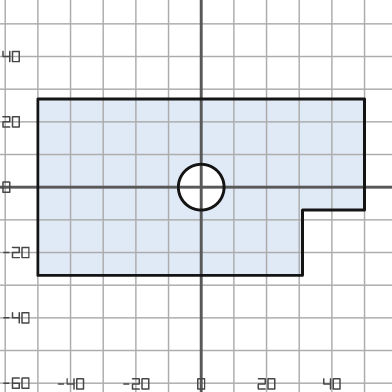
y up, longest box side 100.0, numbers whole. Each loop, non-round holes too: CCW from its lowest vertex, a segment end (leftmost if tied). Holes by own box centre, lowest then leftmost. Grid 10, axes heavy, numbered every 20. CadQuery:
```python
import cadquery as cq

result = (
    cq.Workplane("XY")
    .moveTo(-50.0, -27.0)
    .lineTo(31.0, -27.0)
    .lineTo(31.0, -7.0)
    .lineTo(50.0, -7.0)
    .lineTo(50.0, 27.0)
    .lineTo(-50.0, 27.0)
    .close()
    .moveTo(0.0, 0.0)
    .circle(7.0)
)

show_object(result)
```